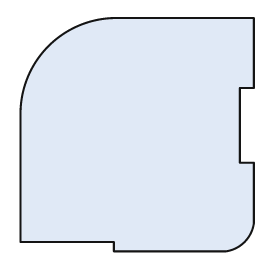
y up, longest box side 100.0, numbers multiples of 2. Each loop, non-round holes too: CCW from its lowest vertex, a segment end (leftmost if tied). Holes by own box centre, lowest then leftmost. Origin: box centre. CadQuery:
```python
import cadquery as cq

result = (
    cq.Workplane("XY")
    .moveTo(-10.0, -50.0)
    .lineTo(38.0, -50.0)
    .threePointArc((46.0, -46.0), (50.0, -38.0))
    .lineTo(50.0, -12.0)
    .lineTo(44.0, -12.0)
    .lineTo(44.0, 20.0)
    .lineTo(50.0, 20.0)
    .lineTo(50.0, 50.0)
    .lineTo(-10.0, 50.0)
    .threePointArc((-38.0, 38.0), (-50.0, 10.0))
    .lineTo(-50.0, -46.0)
    .lineTo(-10.0, -46.0)
    .close()
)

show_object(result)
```